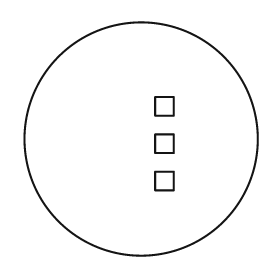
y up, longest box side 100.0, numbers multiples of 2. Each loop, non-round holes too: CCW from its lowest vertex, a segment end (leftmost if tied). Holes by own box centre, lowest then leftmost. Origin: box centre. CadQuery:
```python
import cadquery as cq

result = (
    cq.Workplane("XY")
    .moveTo(0.0, 0.0)
    .circle(50.0)
    .moveTo(6.0, -22.0)
    .lineTo(14.0, -22.0)
    .lineTo(14.0, -14.0)
    .lineTo(6.0, -14.0)
    .close()
    .moveTo(6.0, -6.0)
    .lineTo(14.0, -6.0)
    .lineTo(14.0, 2.0)
    .lineTo(6.0, 2.0)
    .close()
    .moveTo(6.0, 10.0)
    .lineTo(14.0, 10.0)
    .lineTo(14.0, 18.0)
    .lineTo(6.0, 18.0)
    .close()
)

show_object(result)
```